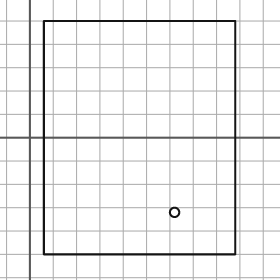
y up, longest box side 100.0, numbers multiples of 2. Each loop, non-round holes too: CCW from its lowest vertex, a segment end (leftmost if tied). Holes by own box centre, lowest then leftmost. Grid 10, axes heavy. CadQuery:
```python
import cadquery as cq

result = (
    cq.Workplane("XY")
    .moveTo(6.0, -50.0)
    .lineTo(88.0, -50.0)
    .lineTo(88.0, 50.0)
    .lineTo(6.0, 50.0)
    .close()
    .moveTo(62.0, -32.0)
    .circle(2.0)
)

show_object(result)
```